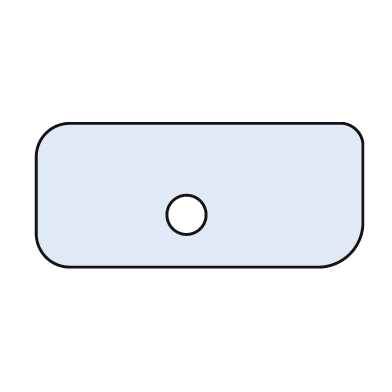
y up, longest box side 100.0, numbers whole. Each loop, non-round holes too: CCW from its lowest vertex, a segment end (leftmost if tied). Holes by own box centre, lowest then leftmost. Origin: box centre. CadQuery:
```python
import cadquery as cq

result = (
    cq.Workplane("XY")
    .moveTo(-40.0, -22.0)
    .lineTo(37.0, -22.0)
    .threePointArc((46.0, -18.0), (50.0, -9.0))
    .lineTo(50.0, 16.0)
    .threePointArc((48.0, 20.0), (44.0, 22.0))
    .lineTo(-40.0, 22.0)
    .threePointArc((-47.0, 19.0), (-50.0, 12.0))
    .lineTo(-50.0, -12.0)
    .threePointArc((-47.0, -19.0), (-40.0, -22.0))
    .close()
    .moveTo(-4.0, -6.0)
    .circle(6.0)
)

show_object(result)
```